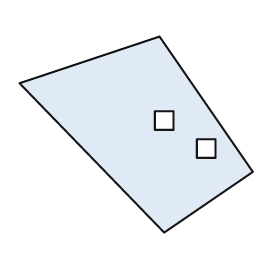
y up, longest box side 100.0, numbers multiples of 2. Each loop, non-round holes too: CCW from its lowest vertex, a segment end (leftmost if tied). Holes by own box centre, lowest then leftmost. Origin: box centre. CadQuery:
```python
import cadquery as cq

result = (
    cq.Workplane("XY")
    .moveTo(12.0, -42.0)
    .lineTo(50.0, -16.0)
    .lineTo(10.0, 42.0)
    .lineTo(-50.0, 22.0)
    .close()
    .moveTo(26.0, -10.0)
    .lineTo(34.0, -10.0)
    .lineTo(34.0, -2.0)
    .lineTo(26.0, -2.0)
    .close()
    .moveTo(8.0, 2.0)
    .lineTo(16.0, 2.0)
    .lineTo(16.0, 10.0)
    .lineTo(8.0, 10.0)
    .close()
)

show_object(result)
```